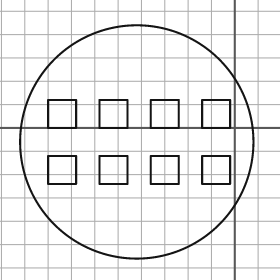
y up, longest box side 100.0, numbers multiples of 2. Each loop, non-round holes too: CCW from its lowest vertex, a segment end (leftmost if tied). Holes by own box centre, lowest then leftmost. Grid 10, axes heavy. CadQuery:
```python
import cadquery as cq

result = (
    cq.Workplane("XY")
    .moveTo(-42.0, -6.0)
    .circle(50.0)
    .moveTo(-80.0, -24.0)
    .lineTo(-68.0, -24.0)
    .lineTo(-68.0, -12.0)
    .lineTo(-80.0, -12.0)
    .close()
    .moveTo(-58.0, -24.0)
    .lineTo(-46.0, -24.0)
    .lineTo(-46.0, -12.0)
    .lineTo(-58.0, -12.0)
    .close()
    .moveTo(-36.0, -24.0)
    .lineTo(-24.0, -24.0)
    .lineTo(-24.0, -12.0)
    .lineTo(-36.0, -12.0)
    .close()
    .moveTo(-14.0, -24.0)
    .lineTo(-2.0, -24.0)
    .lineTo(-2.0, -12.0)
    .lineTo(-14.0, -12.0)
    .close()
    .moveTo(-80.0, 0.0)
    .lineTo(-68.0, 0.0)
    .lineTo(-68.0, 12.0)
    .lineTo(-80.0, 12.0)
    .close()
    .moveTo(-58.0, 0.0)
    .lineTo(-46.0, 0.0)
    .lineTo(-46.0, 12.0)
    .lineTo(-58.0, 12.0)
    .close()
    .moveTo(-36.0, 0.0)
    .lineTo(-24.0, 0.0)
    .lineTo(-24.0, 12.0)
    .lineTo(-36.0, 12.0)
    .close()
    .moveTo(-14.0, 0.0)
    .lineTo(-2.0, 0.0)
    .lineTo(-2.0, 12.0)
    .lineTo(-14.0, 12.0)
    .close()
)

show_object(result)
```